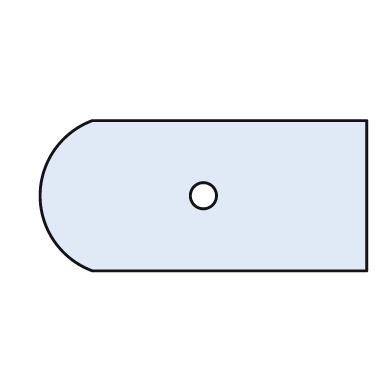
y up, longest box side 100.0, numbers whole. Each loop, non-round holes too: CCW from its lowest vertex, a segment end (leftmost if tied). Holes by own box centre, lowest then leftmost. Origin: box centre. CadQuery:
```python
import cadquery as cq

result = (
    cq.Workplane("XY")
    .moveTo(-34.0, -23.0)
    .lineTo(50.0, -23.0)
    .lineTo(50.0, 23.0)
    .lineTo(-34.0, 23.0)
    .threePointArc((-50.0, 0.0), (-34.0, -23.0))
    .close()
    .moveTo(0.0, 0.0)
    .circle(4.0)
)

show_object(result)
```